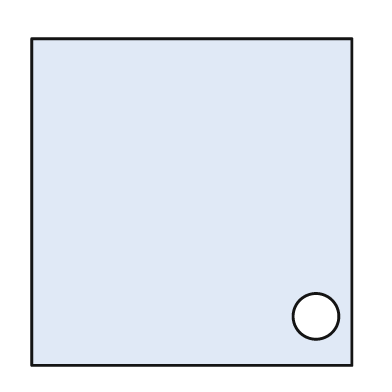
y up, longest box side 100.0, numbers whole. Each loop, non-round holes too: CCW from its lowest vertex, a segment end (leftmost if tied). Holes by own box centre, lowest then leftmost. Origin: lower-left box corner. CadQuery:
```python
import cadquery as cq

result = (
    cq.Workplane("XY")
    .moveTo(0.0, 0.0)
    .lineTo(98.0, 0.0)
    .lineTo(98.0, 100.0)
    .lineTo(0.0, 100.0)
    .close()
    .moveTo(87.0, 15.0)
    .circle(7.0)
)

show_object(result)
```